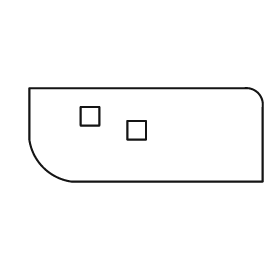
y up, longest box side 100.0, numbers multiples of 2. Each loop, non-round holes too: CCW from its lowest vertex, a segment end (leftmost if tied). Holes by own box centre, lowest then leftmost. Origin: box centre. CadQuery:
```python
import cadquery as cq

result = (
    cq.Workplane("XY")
    .moveTo(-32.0, -20.0)
    .lineTo(50.0, -20.0)
    .lineTo(50.0, 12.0)
    .threePointArc((48.0, 18.0), (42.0, 20.0))
    .lineTo(-50.0, 20.0)
    .lineTo(-50.0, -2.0)
    .threePointArc((-44.0, -14.0), (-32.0, -20.0))
    .close()
    .moveTo(-8.0, -2.0)
    .lineTo(0.0, -2.0)
    .lineTo(0.0, 6.0)
    .lineTo(-8.0, 6.0)
    .close()
    .moveTo(-28.0, 4.0)
    .lineTo(-20.0, 4.0)
    .lineTo(-20.0, 12.0)
    .lineTo(-28.0, 12.0)
    .close()
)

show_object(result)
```